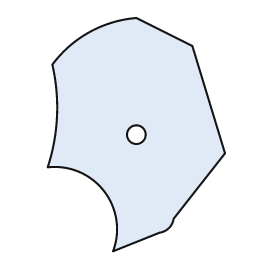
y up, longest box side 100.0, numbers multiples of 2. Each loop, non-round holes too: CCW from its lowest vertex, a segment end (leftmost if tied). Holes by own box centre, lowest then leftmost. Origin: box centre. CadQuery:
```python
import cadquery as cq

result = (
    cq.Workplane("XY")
    .moveTo(-10.0, -50.0)
    .lineTo(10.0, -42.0)
    .threePointArc((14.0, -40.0), (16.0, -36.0))
    .lineTo(38.0, -8.0)
    .lineTo(24.0, 38.0)
    .lineTo(0.0, 50.0)
    .threePointArc((-20.0, 44.0), (-36.0, 30.0))
    .threePointArc((-34.0, 8.0), (-38.0, -14.0))
    .threePointArc((-14.0, -24.0), (-10.0, -50.0))
    .close()
    .moveTo(0.0, 0.0)
    .circle(4.0)
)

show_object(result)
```